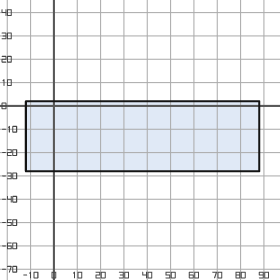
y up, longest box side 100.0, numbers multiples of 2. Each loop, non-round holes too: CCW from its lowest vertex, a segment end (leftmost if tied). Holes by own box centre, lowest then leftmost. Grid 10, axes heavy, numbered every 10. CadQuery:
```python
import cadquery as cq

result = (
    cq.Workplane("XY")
    .moveTo(-12.0, -28.0)
    .lineTo(88.0, -28.0)
    .lineTo(88.0, 2.0)
    .lineTo(-12.0, 2.0)
    .close()
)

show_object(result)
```